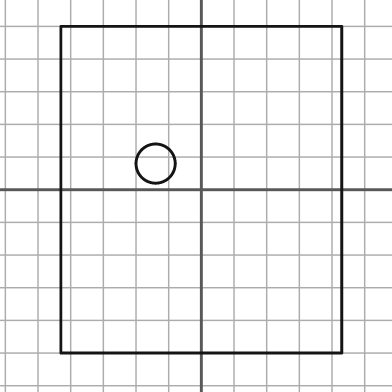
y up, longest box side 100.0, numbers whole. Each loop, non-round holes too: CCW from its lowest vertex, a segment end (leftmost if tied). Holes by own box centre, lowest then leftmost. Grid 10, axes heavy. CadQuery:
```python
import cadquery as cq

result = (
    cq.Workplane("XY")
    .moveTo(-43.0, -50.0)
    .lineTo(43.0, -50.0)
    .lineTo(43.0, 50.0)
    .lineTo(-43.0, 50.0)
    .close()
    .moveTo(-14.0, 8.0)
    .circle(6.0)
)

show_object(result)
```